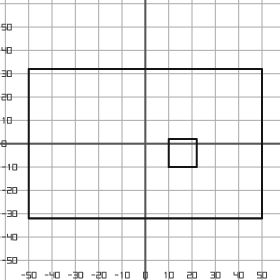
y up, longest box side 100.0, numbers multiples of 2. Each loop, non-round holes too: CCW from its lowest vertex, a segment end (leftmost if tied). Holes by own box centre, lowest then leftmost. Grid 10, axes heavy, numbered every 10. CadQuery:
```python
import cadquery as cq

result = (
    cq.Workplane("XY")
    .moveTo(-50.0, -32.0)
    .lineTo(50.0, -32.0)
    .lineTo(50.0, 32.0)
    .lineTo(-50.0, 32.0)
    .close()
    .moveTo(10.0, -10.0)
    .lineTo(22.0, -10.0)
    .lineTo(22.0, 2.0)
    .lineTo(10.0, 2.0)
    .close()
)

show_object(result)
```